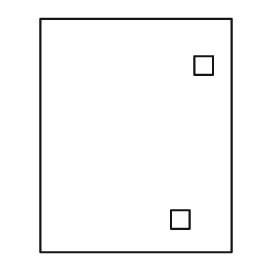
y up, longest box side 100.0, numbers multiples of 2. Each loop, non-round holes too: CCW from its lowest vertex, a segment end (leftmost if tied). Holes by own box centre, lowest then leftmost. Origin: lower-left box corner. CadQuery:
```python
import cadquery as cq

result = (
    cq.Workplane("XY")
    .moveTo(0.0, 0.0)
    .lineTo(82.0, 0.0)
    .lineTo(82.0, 100.0)
    .lineTo(0.0, 100.0)
    .close()
    .moveTo(56.0, 10.0)
    .lineTo(64.0, 10.0)
    .lineTo(64.0, 18.0)
    .lineTo(56.0, 18.0)
    .close()
    .moveTo(66.0, 76.0)
    .lineTo(74.0, 76.0)
    .lineTo(74.0, 84.0)
    .lineTo(66.0, 84.0)
    .close()
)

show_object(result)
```